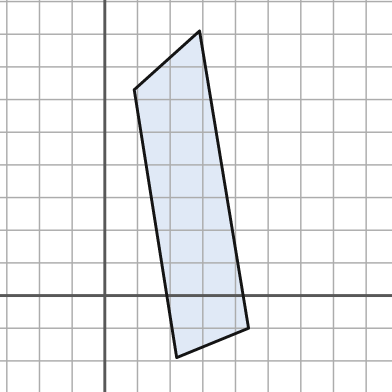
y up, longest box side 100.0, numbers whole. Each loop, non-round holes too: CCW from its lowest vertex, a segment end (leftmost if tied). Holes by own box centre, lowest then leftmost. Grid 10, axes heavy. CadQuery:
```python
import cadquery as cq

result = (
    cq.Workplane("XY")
    .moveTo(22.0, -19.0)
    .lineTo(44.0, -10.0)
    .lineTo(29.0, 81.0)
    .lineTo(9.0, 63.0)
    .close()
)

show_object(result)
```